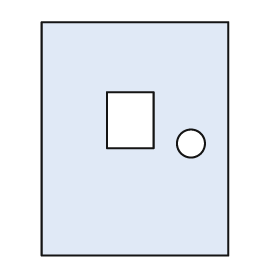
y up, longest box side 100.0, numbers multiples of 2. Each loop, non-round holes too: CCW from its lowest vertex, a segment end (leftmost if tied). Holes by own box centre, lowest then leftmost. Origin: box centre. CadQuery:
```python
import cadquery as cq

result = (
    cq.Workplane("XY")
    .moveTo(-40.0, -50.0)
    .lineTo(40.0, -50.0)
    .lineTo(40.0, 50.0)
    .lineTo(-40.0, 50.0)
    .close()
    .moveTo(24.0, -2.0)
    .circle(6.0)
    .moveTo(-12.0, -4.0)
    .lineTo(8.0, -4.0)
    .lineTo(8.0, 20.0)
    .lineTo(-12.0, 20.0)
    .close()
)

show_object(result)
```